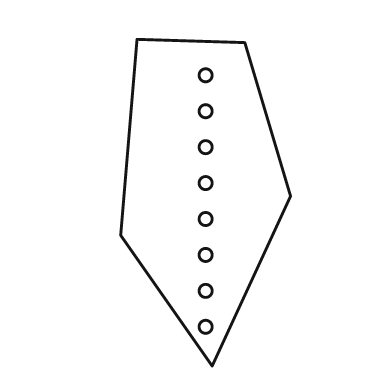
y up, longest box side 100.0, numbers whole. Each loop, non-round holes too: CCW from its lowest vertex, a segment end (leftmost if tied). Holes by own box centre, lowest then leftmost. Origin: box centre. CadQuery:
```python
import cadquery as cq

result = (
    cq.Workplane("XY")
    .moveTo(2.0, -50.0)
    .lineTo(26.0, 2.0)
    .lineTo(12.0, 49.0)
    .lineTo(-21.0, 50.0)
    .lineTo(-26.0, -10.0)
    .close()
    .moveTo(0.0, -38.0)
    .circle(2.0)
    .moveTo(0.0, -27.0)
    .circle(2.0)
    .moveTo(0.0, -16.0)
    .circle(2.0)
    .moveTo(0.0, -5.0)
    .circle(2.0)
    .moveTo(0.0, 6.0)
    .circle(2.0)
    .moveTo(0.0, 17.0)
    .circle(2.0)
    .moveTo(0.0, 28.0)
    .circle(2.0)
    .moveTo(0.0, 39.0)
    .circle(2.0)
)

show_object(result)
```